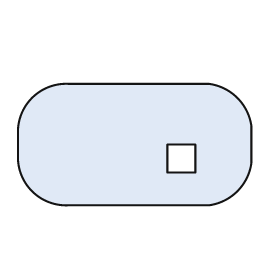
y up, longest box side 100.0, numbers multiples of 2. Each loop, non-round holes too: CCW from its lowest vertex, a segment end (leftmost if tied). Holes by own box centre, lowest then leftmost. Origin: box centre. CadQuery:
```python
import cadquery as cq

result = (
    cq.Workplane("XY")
    .moveTo(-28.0, -26.0)
    .lineTo(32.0, -26.0)
    .threePointArc((44.0, -20.0), (50.0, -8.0))
    .lineTo(50.0, 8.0)
    .threePointArc((44.0, 20.0), (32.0, 26.0))
    .lineTo(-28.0, 26.0)
    .threePointArc((-44.0, 20.0), (-50.0, 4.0))
    .lineTo(-50.0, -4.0)
    .threePointArc((-44.0, -20.0), (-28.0, -26.0))
    .close()
    .moveTo(14.0, -12.0)
    .lineTo(26.0, -12.0)
    .lineTo(26.0, 0.0)
    .lineTo(14.0, 0.0)
    .close()
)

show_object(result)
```